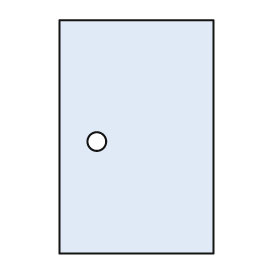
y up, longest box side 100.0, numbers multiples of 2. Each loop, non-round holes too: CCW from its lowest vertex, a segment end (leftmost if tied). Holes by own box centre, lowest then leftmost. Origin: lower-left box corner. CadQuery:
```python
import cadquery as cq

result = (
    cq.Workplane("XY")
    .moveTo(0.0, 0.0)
    .lineTo(66.0, 0.0)
    .lineTo(66.0, 100.0)
    .lineTo(0.0, 100.0)
    .close()
    .moveTo(16.0, 48.0)
    .circle(4.0)
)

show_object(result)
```